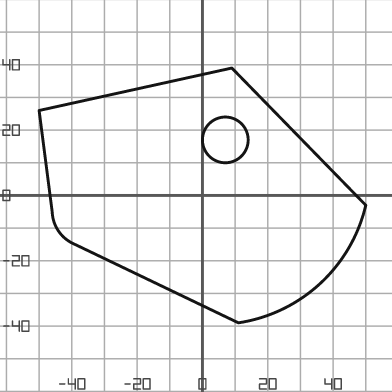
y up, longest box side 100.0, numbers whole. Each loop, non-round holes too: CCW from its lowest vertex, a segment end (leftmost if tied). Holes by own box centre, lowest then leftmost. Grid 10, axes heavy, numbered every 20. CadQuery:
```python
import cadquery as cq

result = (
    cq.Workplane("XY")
    .moveTo(11.0, -39.0)
    .threePointArc((36.0, -27.0), (50.0, -3.0))
    .lineTo(9.0, 39.0)
    .lineTo(-50.0, 26.0)
    .lineTo(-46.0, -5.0)
    .threePointArc((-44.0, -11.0), (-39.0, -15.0))
    .close()
    .moveTo(7.0, 17.0)
    .circle(7.0)
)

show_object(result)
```